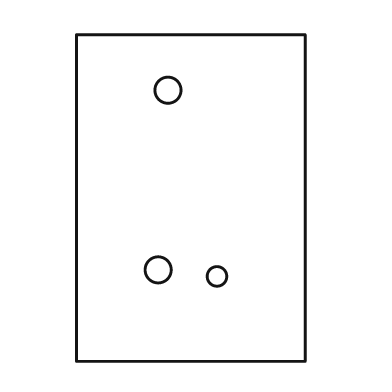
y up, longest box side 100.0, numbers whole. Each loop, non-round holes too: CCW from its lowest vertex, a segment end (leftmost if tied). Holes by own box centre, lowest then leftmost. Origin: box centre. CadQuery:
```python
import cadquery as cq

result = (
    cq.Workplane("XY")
    .moveTo(-35.0, -50.0)
    .lineTo(35.0, -50.0)
    .lineTo(35.0, 50.0)
    .lineTo(-35.0, 50.0)
    .close()
    .moveTo(8.0, -24.0)
    .circle(3.0)
    .moveTo(-10.0, -22.0)
    .circle(4.0)
    .moveTo(-7.0, 33.0)
    .circle(4.0)
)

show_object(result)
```